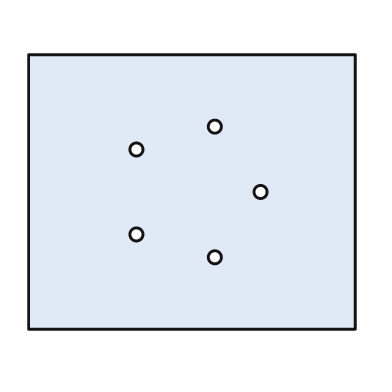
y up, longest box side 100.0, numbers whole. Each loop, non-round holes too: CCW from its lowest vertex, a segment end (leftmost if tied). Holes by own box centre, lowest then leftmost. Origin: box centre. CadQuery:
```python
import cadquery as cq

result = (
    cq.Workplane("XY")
    .moveTo(-50.0, -42.0)
    .lineTo(50.0, -42.0)
    .lineTo(50.0, 42.0)
    .lineTo(-50.0, 42.0)
    .close()
    .moveTo(7.0, -20.0)
    .circle(2.0)
    .moveTo(-17.0, -13.0)
    .circle(2.0)
    .moveTo(21.0, 0.0)
    .circle(2.0)
    .moveTo(-17.0, 13.0)
    .circle(2.0)
    .moveTo(7.0, 20.0)
    .circle(2.0)
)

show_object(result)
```